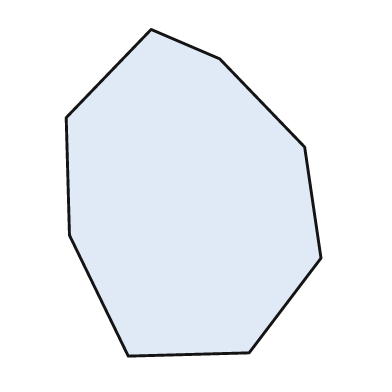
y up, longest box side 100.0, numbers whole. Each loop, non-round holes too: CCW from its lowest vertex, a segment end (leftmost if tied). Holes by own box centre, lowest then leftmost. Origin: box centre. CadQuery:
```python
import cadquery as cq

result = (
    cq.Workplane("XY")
    .moveTo(-20.0, -50.0)
    .lineTo(17.0, -49.0)
    .lineTo(39.0, -20.0)
    .lineTo(34.0, 14.0)
    .lineTo(8.0, 41.0)
    .lineTo(-13.0, 50.0)
    .lineTo(-39.0, 23.0)
    .lineTo(-38.0, -13.0)
    .close()
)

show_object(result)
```